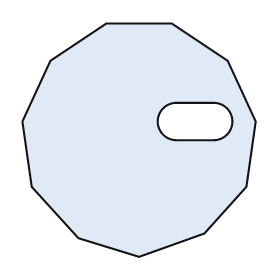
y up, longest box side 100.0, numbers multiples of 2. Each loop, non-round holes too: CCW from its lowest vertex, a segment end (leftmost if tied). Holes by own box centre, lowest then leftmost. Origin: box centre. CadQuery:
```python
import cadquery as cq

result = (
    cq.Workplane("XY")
    .moveTo(0.0, -50.0)
    .lineTo(28.0, -40.0)
    .lineTo(46.0, -20.0)
    .lineTo(50.0, 8.0)
    .lineTo(38.0, 34.0)
    .lineTo(14.0, 50.0)
    .lineTo(-14.0, 50.0)
    .lineTo(-38.0, 34.0)
    .lineTo(-50.0, 8.0)
    .lineTo(-46.0, -20.0)
    .lineTo(-26.0, -42.0)
    .close()
    .moveTo(16.0, 0.0)
    .lineTo(32.0, 0.0)
    .threePointArc((40.0, 8.0), (32.0, 16.0))
    .lineTo(16.0, 16.0)
    .threePointArc((8.0, 8.0), (16.0, 0.0))
    .close()
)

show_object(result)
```